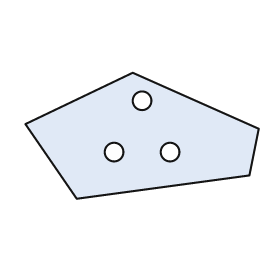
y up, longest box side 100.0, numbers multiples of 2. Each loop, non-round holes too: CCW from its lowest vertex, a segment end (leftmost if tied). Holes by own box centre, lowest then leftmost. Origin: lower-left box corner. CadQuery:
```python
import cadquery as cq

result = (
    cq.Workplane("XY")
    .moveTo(22.0, 0.0)
    .lineTo(96.0, 10.0)
    .lineTo(100.0, 30.0)
    .lineTo(46.0, 54.0)
    .lineTo(0.0, 32.0)
    .close()
    .moveTo(38.0, 20.0)
    .circle(4.0)
    .moveTo(62.0, 20.0)
    .circle(4.0)
    .moveTo(50.0, 42.0)
    .circle(4.0)
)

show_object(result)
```